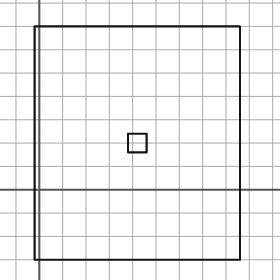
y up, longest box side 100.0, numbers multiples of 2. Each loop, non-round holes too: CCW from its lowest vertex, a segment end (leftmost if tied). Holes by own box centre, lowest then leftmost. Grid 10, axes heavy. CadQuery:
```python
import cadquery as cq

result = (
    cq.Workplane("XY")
    .moveTo(-2.0, -30.0)
    .lineTo(86.0, -30.0)
    .lineTo(86.0, 70.0)
    .lineTo(-2.0, 70.0)
    .close()
    .moveTo(38.0, 16.0)
    .lineTo(46.0, 16.0)
    .lineTo(46.0, 24.0)
    .lineTo(38.0, 24.0)
    .close()
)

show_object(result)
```